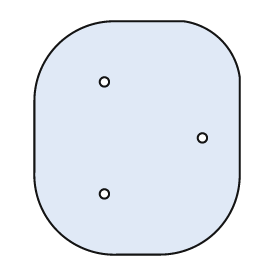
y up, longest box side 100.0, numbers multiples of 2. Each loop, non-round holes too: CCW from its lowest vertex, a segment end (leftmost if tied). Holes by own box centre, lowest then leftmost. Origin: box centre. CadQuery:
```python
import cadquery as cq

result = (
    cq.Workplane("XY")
    .moveTo(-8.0, -50.0)
    .lineTo(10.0, -50.0)
    .threePointArc((34.0, -40.0), (44.0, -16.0))
    .lineTo(44.0, 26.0)
    .threePointArc((36.0, 42.0), (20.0, 50.0))
    .lineTo(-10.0, 50.0)
    .threePointArc((-34.0, 40.0), (-44.0, 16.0))
    .lineTo(-44.0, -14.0)
    .threePointArc((-34.0, -40.0), (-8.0, -50.0))
    .close()
    .moveTo(-14.0, -24.0)
    .circle(2.0)
    .moveTo(28.0, 0.0)
    .circle(2.0)
    .moveTo(-14.0, 24.0)
    .circle(2.0)
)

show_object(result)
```